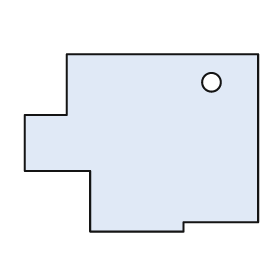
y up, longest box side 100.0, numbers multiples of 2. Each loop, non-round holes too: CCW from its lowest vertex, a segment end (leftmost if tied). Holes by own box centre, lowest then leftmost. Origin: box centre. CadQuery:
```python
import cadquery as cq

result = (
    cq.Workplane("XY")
    .moveTo(-22.0, -38.0)
    .lineTo(18.0, -38.0)
    .lineTo(18.0, -34.0)
    .lineTo(50.0, -34.0)
    .lineTo(50.0, 38.0)
    .lineTo(-32.0, 38.0)
    .lineTo(-32.0, 12.0)
    .lineTo(-50.0, 12.0)
    .lineTo(-50.0, -12.0)
    .lineTo(-22.0, -12.0)
    .close()
    .moveTo(30.0, 26.0)
    .circle(4.0)
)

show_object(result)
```